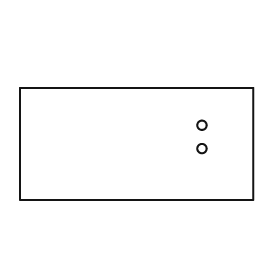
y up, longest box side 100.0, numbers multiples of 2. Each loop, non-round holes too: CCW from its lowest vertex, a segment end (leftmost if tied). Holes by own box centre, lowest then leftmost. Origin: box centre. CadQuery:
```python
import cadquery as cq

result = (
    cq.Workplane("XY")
    .moveTo(-50.0, -24.0)
    .lineTo(50.0, -24.0)
    .lineTo(50.0, 24.0)
    .lineTo(-50.0, 24.0)
    .close()
    .moveTo(28.0, -2.0)
    .circle(2.0)
    .moveTo(28.0, 8.0)
    .circle(2.0)
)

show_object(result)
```